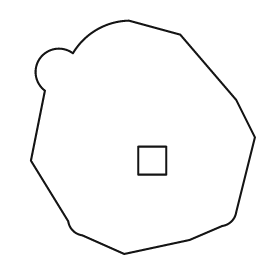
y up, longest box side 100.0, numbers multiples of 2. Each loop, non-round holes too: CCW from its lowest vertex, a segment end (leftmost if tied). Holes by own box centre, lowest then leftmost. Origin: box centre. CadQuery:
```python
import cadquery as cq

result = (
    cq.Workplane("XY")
    .moveTo(-8.0, -50.0)
    .lineTo(20.0, -44.0)
    .lineTo(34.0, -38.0)
    .threePointArc((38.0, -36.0), (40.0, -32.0))
    .lineTo(48.0, 0.0)
    .lineTo(40.0, 16.0)
    .lineTo(16.0, 44.0)
    .lineTo(-6.0, 50.0)
    .threePointArc((-20.0, 46.0), (-30.0, 36.0))
    .threePointArc((-44.0, 34.0), (-42.0, 20.0))
    .lineTo(-48.0, -10.0)
    .lineTo(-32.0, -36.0)
    .threePointArc((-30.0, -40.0), (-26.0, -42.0))
    .close()
    .moveTo(-2.0, -16.0)
    .lineTo(10.0, -16.0)
    .lineTo(10.0, -4.0)
    .lineTo(-2.0, -4.0)
    .close()
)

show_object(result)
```